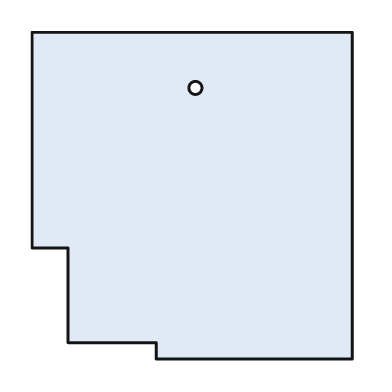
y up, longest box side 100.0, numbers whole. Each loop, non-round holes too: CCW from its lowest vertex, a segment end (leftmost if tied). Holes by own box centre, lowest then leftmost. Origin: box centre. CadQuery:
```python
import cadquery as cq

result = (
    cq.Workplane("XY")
    .moveTo(-11.0, -50.0)
    .lineTo(49.0, -50.0)
    .lineTo(49.0, 50.0)
    .lineTo(-49.0, 50.0)
    .lineTo(-49.0, -16.0)
    .lineTo(-38.0, -16.0)
    .lineTo(-38.0, -45.0)
    .lineTo(-11.0, -45.0)
    .close()
    .moveTo(1.0, 33.0)
    .circle(2.0)
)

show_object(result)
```